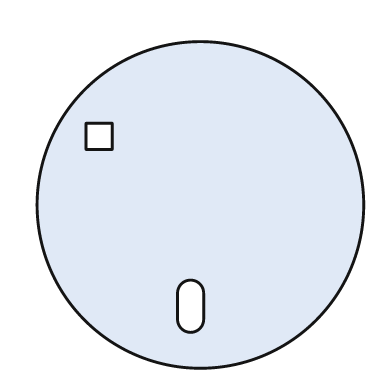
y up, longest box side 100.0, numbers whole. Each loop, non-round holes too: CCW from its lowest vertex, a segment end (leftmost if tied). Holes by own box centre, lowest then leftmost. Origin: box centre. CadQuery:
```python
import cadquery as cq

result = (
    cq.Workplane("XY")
    .moveTo(0.0, 0.0)
    .circle(50.0)
    .moveTo(-7.0, -35.0)
    .threePointArc((-3.0, -39.0), (1.0, -35.0))
    .lineTo(1.0, -27.0)
    .threePointArc((-3.0, -23.0), (-7.0, -27.0))
    .close()
    .moveTo(-35.0, 17.0)
    .lineTo(-27.0, 17.0)
    .lineTo(-27.0, 25.0)
    .lineTo(-35.0, 25.0)
    .close()
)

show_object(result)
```